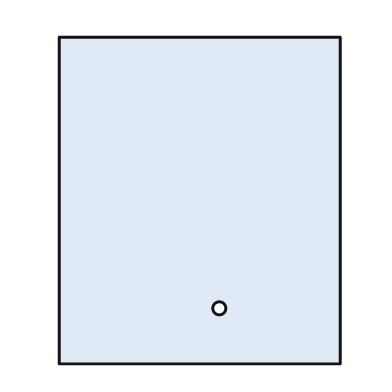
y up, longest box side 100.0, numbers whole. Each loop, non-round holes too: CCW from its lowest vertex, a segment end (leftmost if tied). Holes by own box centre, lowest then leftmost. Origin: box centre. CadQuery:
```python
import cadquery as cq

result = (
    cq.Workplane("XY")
    .moveTo(-43.0, -50.0)
    .lineTo(43.0, -50.0)
    .lineTo(43.0, 50.0)
    .lineTo(-43.0, 50.0)
    .close()
    .moveTo(6.0, -33.0)
    .circle(2.0)
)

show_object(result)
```